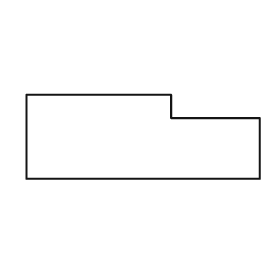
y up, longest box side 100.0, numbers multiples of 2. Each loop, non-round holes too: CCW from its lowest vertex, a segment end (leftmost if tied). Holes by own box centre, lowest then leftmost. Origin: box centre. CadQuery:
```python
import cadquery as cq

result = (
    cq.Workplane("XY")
    .moveTo(-50.0, -18.0)
    .lineTo(50.0, -18.0)
    .lineTo(50.0, 8.0)
    .lineTo(12.0, 8.0)
    .lineTo(12.0, 18.0)
    .lineTo(-50.0, 18.0)
    .close()
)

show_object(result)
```